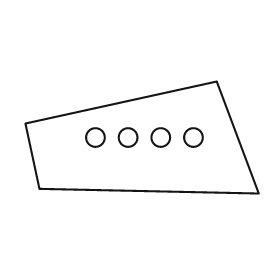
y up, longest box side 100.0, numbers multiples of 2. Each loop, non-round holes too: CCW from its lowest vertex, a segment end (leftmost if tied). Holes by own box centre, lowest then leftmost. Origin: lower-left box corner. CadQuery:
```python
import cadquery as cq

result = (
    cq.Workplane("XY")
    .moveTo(100.0, 0.0)
    .lineTo(82.0, 48.0)
    .lineTo(0.0, 30.0)
    .lineTo(6.0, 2.0)
    .close()
    .moveTo(30.0, 24.0)
    .circle(4.0)
    .moveTo(44.0, 24.0)
    .circle(4.0)
    .moveTo(58.0, 24.0)
    .circle(4.0)
    .moveTo(72.0, 24.0)
    .circle(4.0)
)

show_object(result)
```